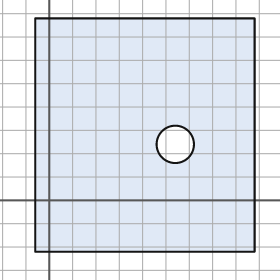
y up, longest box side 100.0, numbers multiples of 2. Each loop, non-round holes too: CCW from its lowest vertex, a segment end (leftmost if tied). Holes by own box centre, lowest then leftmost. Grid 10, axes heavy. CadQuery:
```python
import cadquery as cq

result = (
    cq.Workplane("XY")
    .moveTo(-6.0, -22.0)
    .lineTo(88.0, -22.0)
    .lineTo(88.0, 78.0)
    .lineTo(-6.0, 78.0)
    .close()
    .moveTo(54.0, 24.0)
    .circle(8.0)
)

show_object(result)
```